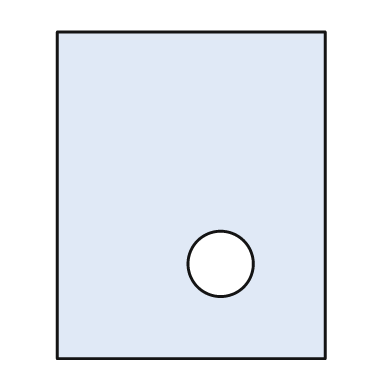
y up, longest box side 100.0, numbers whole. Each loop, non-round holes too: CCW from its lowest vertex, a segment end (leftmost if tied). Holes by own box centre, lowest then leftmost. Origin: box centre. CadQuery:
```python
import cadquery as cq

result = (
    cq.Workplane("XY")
    .moveTo(-41.0, -50.0)
    .lineTo(41.0, -50.0)
    .lineTo(41.0, 50.0)
    .lineTo(-41.0, 50.0)
    .close()
    .moveTo(9.0, -21.0)
    .circle(10.0)
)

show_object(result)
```